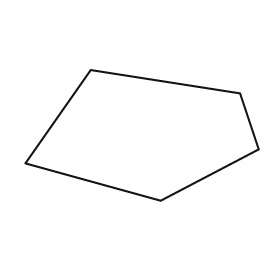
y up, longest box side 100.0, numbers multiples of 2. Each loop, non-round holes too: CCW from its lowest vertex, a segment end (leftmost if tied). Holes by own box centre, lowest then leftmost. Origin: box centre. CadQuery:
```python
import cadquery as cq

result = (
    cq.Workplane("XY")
    .moveTo(8.0, -28.0)
    .lineTo(50.0, -6.0)
    .lineTo(42.0, 18.0)
    .lineTo(-22.0, 28.0)
    .lineTo(-50.0, -12.0)
    .close()
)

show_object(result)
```